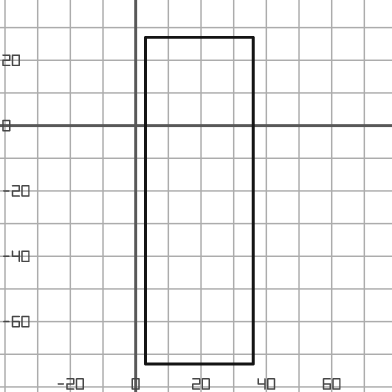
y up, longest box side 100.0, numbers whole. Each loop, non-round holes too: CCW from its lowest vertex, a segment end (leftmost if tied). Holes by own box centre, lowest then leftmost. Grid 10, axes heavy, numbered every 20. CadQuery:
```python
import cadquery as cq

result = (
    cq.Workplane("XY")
    .moveTo(3.0, -73.0)
    .lineTo(36.0, -73.0)
    .lineTo(36.0, 27.0)
    .lineTo(3.0, 27.0)
    .close()
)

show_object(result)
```